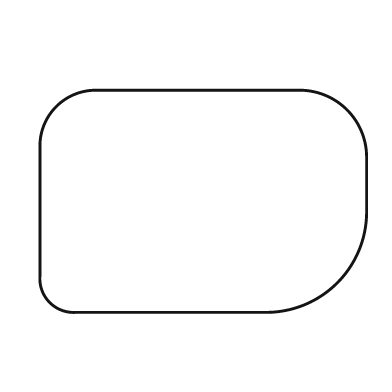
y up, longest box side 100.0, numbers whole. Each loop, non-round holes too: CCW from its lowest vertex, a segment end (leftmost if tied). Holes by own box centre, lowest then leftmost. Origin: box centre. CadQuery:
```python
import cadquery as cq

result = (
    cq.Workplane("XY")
    .moveTo(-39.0, -34.0)
    .lineTo(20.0, -34.0)
    .threePointArc((41.0, -25.0), (50.0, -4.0))
    .lineTo(50.0, 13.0)
    .threePointArc((44.0, 28.0), (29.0, 34.0))
    .lineTo(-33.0, 34.0)
    .threePointArc((-45.0, 29.0), (-50.0, 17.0))
    .lineTo(-50.0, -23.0)
    .threePointArc((-47.0, -31.0), (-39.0, -34.0))
    .close()
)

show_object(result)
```